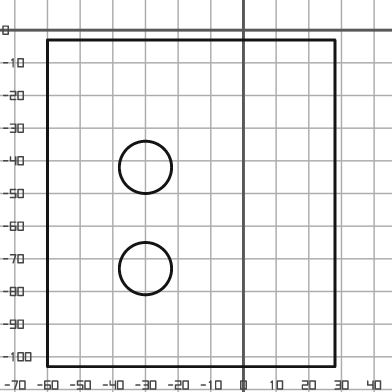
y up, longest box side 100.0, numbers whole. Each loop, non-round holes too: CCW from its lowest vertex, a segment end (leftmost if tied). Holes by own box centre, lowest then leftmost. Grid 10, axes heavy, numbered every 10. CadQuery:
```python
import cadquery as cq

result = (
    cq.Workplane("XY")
    .moveTo(-60.0, -103.0)
    .lineTo(28.0, -103.0)
    .lineTo(28.0, -3.0)
    .lineTo(-60.0, -3.0)
    .close()
    .moveTo(-30.0, -73.0)
    .circle(8.0)
    .moveTo(-30.0, -42.0)
    .circle(8.0)
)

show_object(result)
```